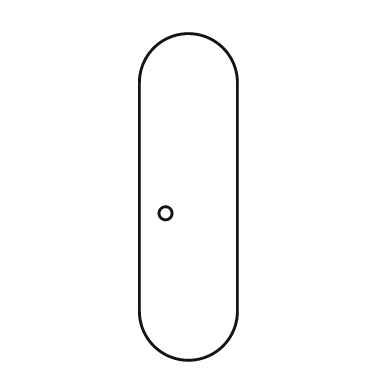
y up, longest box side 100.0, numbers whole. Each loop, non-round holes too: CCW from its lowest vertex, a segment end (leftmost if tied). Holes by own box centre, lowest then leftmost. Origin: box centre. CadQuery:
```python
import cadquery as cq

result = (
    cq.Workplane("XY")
    .moveTo(-15.0, -35.0)
    .threePointArc((0.0, -50.0), (15.0, -35.0))
    .lineTo(15.0, 35.0)
    .threePointArc((0.0, 50.0), (-15.0, 35.0))
    .close()
    .moveTo(-7.0, -5.0)
    .circle(2.0)
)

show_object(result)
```